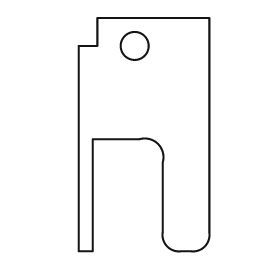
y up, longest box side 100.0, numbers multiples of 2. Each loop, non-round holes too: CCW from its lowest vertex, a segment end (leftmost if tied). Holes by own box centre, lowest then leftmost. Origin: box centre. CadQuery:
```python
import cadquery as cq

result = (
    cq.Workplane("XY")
    .moveTo(-28.0, -50.0)
    .lineTo(-22.0, -50.0)
    .lineTo(-22.0, -2.0)
    .lineTo(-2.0, -2.0)
    .threePointArc((6.0, -4.0), (8.0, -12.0))
    .lineTo(8.0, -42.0)
    .threePointArc((10.0, -48.0), (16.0, -50.0))
    .lineTo(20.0, -50.0)
    .threePointArc((26.0, -48.0), (28.0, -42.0))
    .lineTo(28.0, 50.0)
    .lineTo(-20.0, 50.0)
    .lineTo(-20.0, 38.0)
    .lineTo(-28.0, 38.0)
    .close()
    .moveTo(-4.0, 38.0)
    .circle(6.0)
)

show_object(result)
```